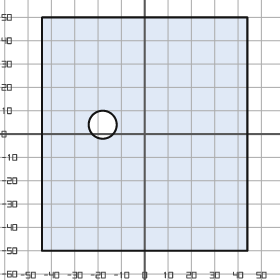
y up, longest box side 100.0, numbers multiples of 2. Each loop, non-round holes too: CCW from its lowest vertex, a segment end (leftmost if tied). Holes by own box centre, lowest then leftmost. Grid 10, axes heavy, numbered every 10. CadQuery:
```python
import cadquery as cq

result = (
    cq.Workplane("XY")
    .moveTo(-44.0, -50.0)
    .lineTo(44.0, -50.0)
    .lineTo(44.0, 50.0)
    .lineTo(-44.0, 50.0)
    .close()
    .moveTo(-18.0, 4.0)
    .circle(6.0)
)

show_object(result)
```